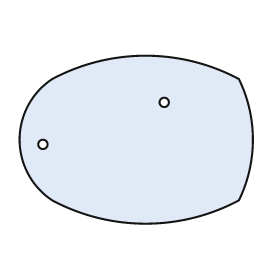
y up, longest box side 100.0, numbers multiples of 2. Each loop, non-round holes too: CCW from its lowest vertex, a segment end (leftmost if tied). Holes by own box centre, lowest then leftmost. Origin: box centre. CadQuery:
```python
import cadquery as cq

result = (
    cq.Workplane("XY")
    .moveTo(-36.0, -26.0)
    .threePointArc((4.0, -36.0), (44.0, -26.0))
    .threePointArc((50.0, 0.0), (44.0, 26.0))
    .threePointArc((4.0, 36.0), (-36.0, 26.0))
    .threePointArc((-50.0, 0.0), (-36.0, -26.0))
    .close()
    .moveTo(-40.0, -2.0)
    .circle(2.0)
    .moveTo(12.0, 16.0)
    .circle(2.0)
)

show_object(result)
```